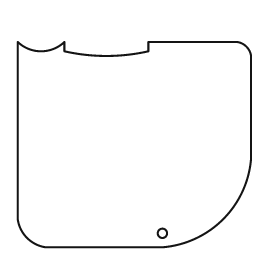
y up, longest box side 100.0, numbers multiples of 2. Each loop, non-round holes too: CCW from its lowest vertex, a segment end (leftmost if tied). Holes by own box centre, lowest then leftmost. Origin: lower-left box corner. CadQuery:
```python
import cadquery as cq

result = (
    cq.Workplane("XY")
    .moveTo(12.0, 0.0)
    .lineTo(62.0, 0.0)
    .threePointArc((88.0, 12.0), (100.0, 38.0))
    .lineTo(100.0, 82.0)
    .threePointArc((98.0, 86.0), (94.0, 88.0))
    .lineTo(56.0, 88.0)
    .lineTo(56.0, 84.0)
    .threePointArc((38.0, 82.0), (20.0, 84.0))
    .lineTo(20.0, 88.0)
    .threePointArc((10.0, 84.0), (0.0, 88.0))
    .lineTo(0.0, 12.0)
    .threePointArc((4.0, 4.0), (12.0, 0.0))
    .close()
    .moveTo(62.0, 6.0)
    .circle(2.0)
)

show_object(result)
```